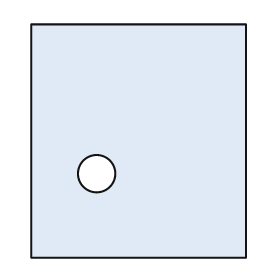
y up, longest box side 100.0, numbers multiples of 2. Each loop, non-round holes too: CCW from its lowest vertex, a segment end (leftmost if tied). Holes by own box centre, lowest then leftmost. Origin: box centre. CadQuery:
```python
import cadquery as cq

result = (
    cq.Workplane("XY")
    .moveTo(-46.0, -50.0)
    .lineTo(46.0, -50.0)
    .lineTo(46.0, 50.0)
    .lineTo(-46.0, 50.0)
    .close()
    .moveTo(-18.0, -14.0)
    .circle(8.0)
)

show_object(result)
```